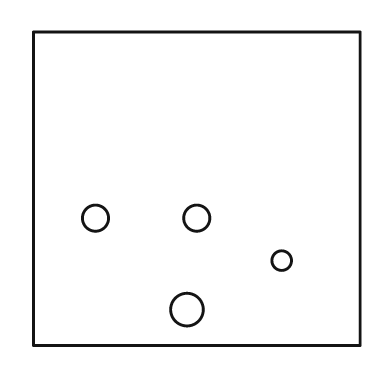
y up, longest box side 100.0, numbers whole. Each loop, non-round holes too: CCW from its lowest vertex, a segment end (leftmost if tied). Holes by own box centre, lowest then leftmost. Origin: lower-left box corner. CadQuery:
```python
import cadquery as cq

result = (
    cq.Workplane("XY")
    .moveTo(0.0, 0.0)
    .lineTo(100.0, 0.0)
    .lineTo(100.0, 96.0)
    .lineTo(0.0, 96.0)
    .close()
    .moveTo(47.0, 11.0)
    .circle(5.0)
    .moveTo(76.0, 26.0)
    .circle(3.0)
    .moveTo(19.0, 39.0)
    .circle(4.0)
    .moveTo(50.0, 39.0)
    .circle(4.0)
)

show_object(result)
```